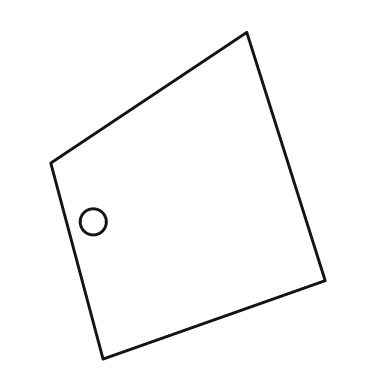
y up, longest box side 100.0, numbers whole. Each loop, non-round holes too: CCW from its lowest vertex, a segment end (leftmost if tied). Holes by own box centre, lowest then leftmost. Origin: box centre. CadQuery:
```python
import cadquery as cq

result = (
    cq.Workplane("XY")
    .moveTo(-26.0, -50.0)
    .lineTo(42.0, -26.0)
    .lineTo(18.0, 50.0)
    .lineTo(-42.0, 10.0)
    .close()
    .moveTo(-29.0, -8.0)
    .circle(4.0)
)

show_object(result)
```